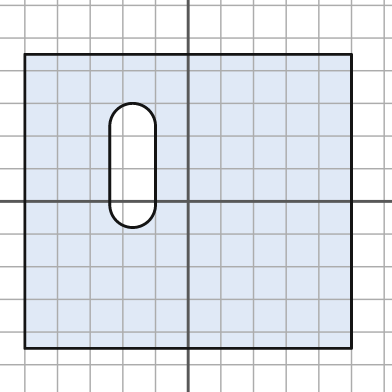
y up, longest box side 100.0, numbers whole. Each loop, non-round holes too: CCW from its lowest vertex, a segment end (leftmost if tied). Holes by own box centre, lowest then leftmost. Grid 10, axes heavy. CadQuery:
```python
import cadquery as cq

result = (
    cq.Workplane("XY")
    .moveTo(-50.0, -45.0)
    .lineTo(50.0, -45.0)
    .lineTo(50.0, 45.0)
    .lineTo(-50.0, 45.0)
    .close()
    .moveTo(-24.0, -1.0)
    .threePointArc((-17.0, -8.0), (-10.0, -1.0))
    .lineTo(-10.0, 23.0)
    .threePointArc((-17.0, 30.0), (-24.0, 23.0))
    .close()
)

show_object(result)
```